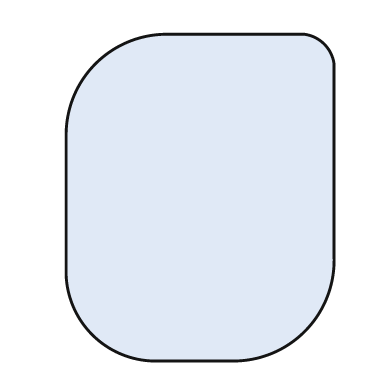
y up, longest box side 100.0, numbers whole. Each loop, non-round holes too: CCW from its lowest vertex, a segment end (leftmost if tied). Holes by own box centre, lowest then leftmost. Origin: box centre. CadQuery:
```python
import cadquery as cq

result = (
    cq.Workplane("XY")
    .moveTo(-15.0, -50.0)
    .lineTo(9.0, -50.0)
    .threePointArc((32.0, -41.0), (41.0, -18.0))
    .lineTo(41.0, 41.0)
    .threePointArc((38.0, 47.0), (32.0, 50.0))
    .lineTo(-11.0, 50.0)
    .threePointArc((-32.0, 41.0), (-41.0, 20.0))
    .lineTo(-41.0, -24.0)
    .threePointArc((-33.0, -42.0), (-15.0, -50.0))
    .close()
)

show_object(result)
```